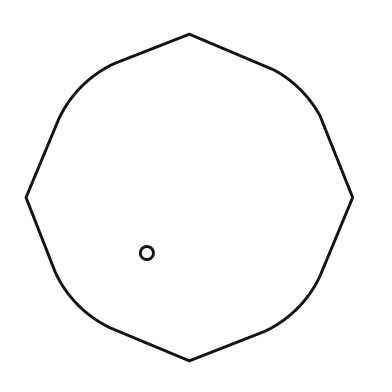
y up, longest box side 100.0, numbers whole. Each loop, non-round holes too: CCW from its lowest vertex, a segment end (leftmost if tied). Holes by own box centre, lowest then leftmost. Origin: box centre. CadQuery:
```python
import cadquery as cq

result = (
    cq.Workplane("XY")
    .moveTo(0.0, -50.0)
    .lineTo(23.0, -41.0)
    .threePointArc((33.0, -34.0), (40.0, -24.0))
    .lineTo(50.0, 0.0)
    .lineTo(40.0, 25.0)
    .threePointArc((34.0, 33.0), (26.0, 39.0))
    .lineTo(0.0, 50.0)
    .lineTo(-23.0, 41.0)
    .threePointArc((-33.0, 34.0), (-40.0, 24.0))
    .lineTo(-50.0, 0.0)
    .lineTo(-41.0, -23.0)
    .threePointArc((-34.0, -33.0), (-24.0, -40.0))
    .close()
    .moveTo(-13.0, -17.0)
    .circle(2.0)
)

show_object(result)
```